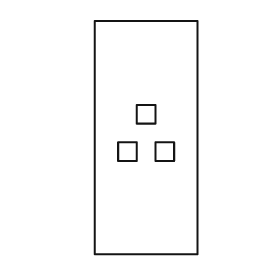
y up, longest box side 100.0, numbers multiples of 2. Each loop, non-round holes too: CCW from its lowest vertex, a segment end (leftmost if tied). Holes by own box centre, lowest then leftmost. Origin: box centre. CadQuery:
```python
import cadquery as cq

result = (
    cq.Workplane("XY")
    .moveTo(-22.0, -50.0)
    .lineTo(22.0, -50.0)
    .lineTo(22.0, 50.0)
    .lineTo(-22.0, 50.0)
    .close()
    .moveTo(-12.0, -10.0)
    .lineTo(-4.0, -10.0)
    .lineTo(-4.0, -2.0)
    .lineTo(-12.0, -2.0)
    .close()
    .moveTo(4.0, -10.0)
    .lineTo(12.0, -10.0)
    .lineTo(12.0, -2.0)
    .lineTo(4.0, -2.0)
    .close()
    .moveTo(-4.0, 6.0)
    .lineTo(4.0, 6.0)
    .lineTo(4.0, 14.0)
    .lineTo(-4.0, 14.0)
    .close()
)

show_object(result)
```